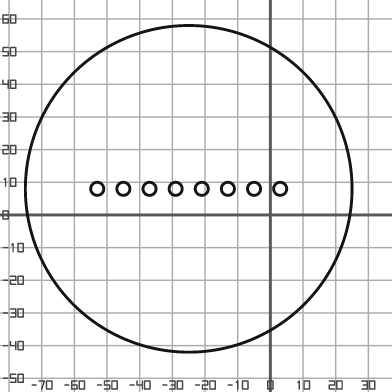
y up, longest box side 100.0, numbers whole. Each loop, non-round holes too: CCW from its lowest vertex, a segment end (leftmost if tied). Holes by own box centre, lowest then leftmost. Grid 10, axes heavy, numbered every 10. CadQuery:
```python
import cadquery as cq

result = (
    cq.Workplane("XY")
    .moveTo(-25.0, 8.0)
    .circle(50.0)
    .moveTo(-53.0, 8.0)
    .circle(2.0)
    .moveTo(-45.0, 8.0)
    .circle(2.0)
    .moveTo(-37.0, 8.0)
    .circle(2.0)
    .moveTo(-29.0, 8.0)
    .circle(2.0)
    .moveTo(-21.0, 8.0)
    .circle(2.0)
    .moveTo(-13.0, 8.0)
    .circle(2.0)
    .moveTo(-5.0, 8.0)
    .circle(2.0)
    .moveTo(3.0, 8.0)
    .circle(2.0)
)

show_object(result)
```